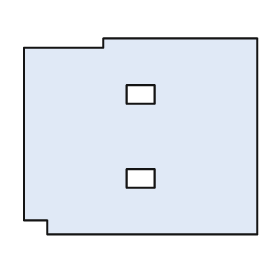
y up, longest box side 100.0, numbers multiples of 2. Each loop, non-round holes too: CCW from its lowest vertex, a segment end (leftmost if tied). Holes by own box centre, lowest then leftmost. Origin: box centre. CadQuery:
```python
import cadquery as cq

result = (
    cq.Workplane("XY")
    .moveTo(-40.0, -42.0)
    .lineTo(50.0, -42.0)
    .lineTo(50.0, 42.0)
    .lineTo(-16.0, 42.0)
    .lineTo(-16.0, 38.0)
    .lineTo(-50.0, 38.0)
    .lineTo(-50.0, -36.0)
    .lineTo(-40.0, -36.0)
    .close()
    .moveTo(-6.0, -22.0)
    .lineTo(6.0, -22.0)
    .lineTo(6.0, -14.0)
    .lineTo(-6.0, -14.0)
    .close()
    .moveTo(-6.0, 14.0)
    .lineTo(6.0, 14.0)
    .lineTo(6.0, 22.0)
    .lineTo(-6.0, 22.0)
    .close()
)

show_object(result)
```